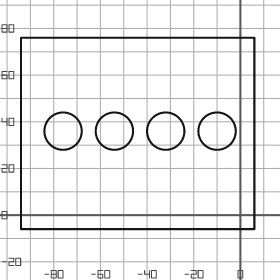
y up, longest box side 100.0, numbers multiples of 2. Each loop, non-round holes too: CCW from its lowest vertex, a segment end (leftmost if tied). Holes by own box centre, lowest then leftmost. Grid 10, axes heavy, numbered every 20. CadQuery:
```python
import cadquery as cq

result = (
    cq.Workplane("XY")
    .moveTo(-94.0, -6.0)
    .lineTo(6.0, -6.0)
    .lineTo(6.0, 76.0)
    .lineTo(-94.0, 76.0)
    .close()
    .moveTo(-76.0, 36.0)
    .circle(8.0)
    .moveTo(-54.0, 36.0)
    .circle(8.0)
    .moveTo(-32.0, 36.0)
    .circle(8.0)
    .moveTo(-10.0, 36.0)
    .circle(8.0)
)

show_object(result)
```